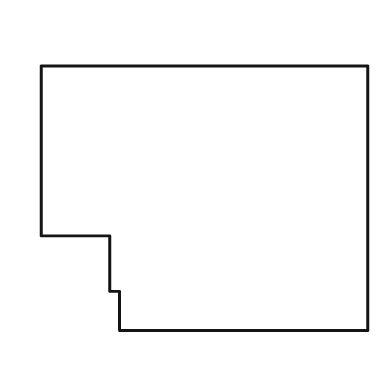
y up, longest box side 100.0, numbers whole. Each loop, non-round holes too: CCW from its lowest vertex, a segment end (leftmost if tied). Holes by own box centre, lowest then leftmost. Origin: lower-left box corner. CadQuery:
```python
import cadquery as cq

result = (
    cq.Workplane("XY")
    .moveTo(24.0, 0.0)
    .lineTo(100.0, 0.0)
    .lineTo(100.0, 81.0)
    .lineTo(0.0, 81.0)
    .lineTo(0.0, 29.0)
    .lineTo(21.0, 29.0)
    .lineTo(21.0, 12.0)
    .lineTo(24.0, 12.0)
    .close()
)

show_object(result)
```